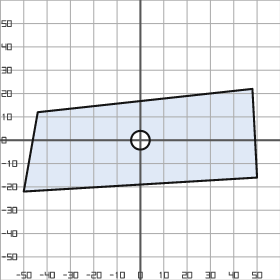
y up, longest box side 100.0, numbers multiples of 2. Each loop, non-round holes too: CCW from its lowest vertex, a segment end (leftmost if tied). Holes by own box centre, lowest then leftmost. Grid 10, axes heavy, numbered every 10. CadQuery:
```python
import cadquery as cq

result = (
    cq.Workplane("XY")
    .moveTo(-50.0, -22.0)
    .lineTo(50.0, -16.0)
    .lineTo(48.0, 22.0)
    .lineTo(-44.0, 12.0)
    .close()
    .moveTo(0.0, 0.0)
    .circle(4.0)
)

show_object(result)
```